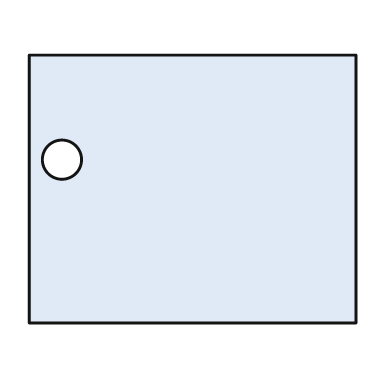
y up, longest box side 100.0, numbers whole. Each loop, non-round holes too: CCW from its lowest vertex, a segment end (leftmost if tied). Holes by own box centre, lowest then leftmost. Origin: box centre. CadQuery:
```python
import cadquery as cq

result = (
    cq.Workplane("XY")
    .moveTo(-50.0, -41.0)
    .lineTo(50.0, -41.0)
    .lineTo(50.0, 41.0)
    .lineTo(-50.0, 41.0)
    .close()
    .moveTo(-40.0, 9.0)
    .circle(6.0)
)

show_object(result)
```